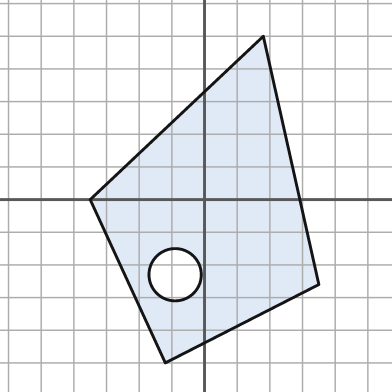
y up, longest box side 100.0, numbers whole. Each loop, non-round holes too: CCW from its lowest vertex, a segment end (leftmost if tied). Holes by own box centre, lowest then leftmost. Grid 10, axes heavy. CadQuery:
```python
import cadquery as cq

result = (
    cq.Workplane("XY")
    .moveTo(-12.0, -50.0)
    .lineTo(35.0, -26.0)
    .lineTo(18.0, 50.0)
    .lineTo(-35.0, 0.0)
    .close()
    .moveTo(-9.0, -23.0)
    .circle(8.0)
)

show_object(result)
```